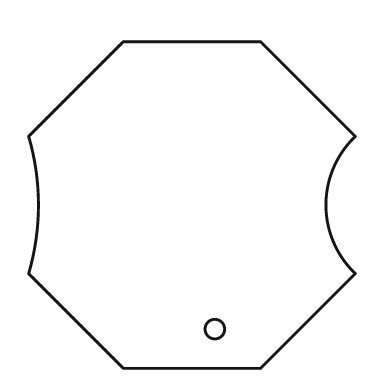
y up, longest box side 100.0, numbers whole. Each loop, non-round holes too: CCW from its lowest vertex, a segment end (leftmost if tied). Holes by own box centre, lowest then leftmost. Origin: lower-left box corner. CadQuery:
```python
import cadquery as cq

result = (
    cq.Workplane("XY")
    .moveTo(29.0, 0.0)
    .lineTo(71.0, 0.0)
    .lineTo(100.0, 29.0)
    .threePointArc((91.0, 50.0), (100.0, 71.0))
    .lineTo(71.0, 100.0)
    .lineTo(29.0, 100.0)
    .lineTo(0.0, 71.0)
    .threePointArc((3.0, 50.0), (0.0, 29.0))
    .close()
    .moveTo(57.0, 12.0)
    .circle(3.0)
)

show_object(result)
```